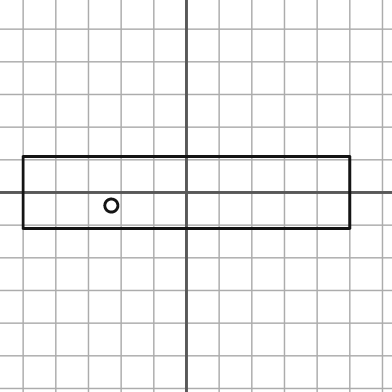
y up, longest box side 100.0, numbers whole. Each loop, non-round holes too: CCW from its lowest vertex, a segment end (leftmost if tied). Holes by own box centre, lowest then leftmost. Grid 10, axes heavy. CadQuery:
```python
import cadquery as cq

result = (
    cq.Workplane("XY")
    .moveTo(-50.0, -11.0)
    .lineTo(50.0, -11.0)
    .lineTo(50.0, 11.0)
    .lineTo(-50.0, 11.0)
    .close()
    .moveTo(-23.0, -4.0)
    .circle(2.0)
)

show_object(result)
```